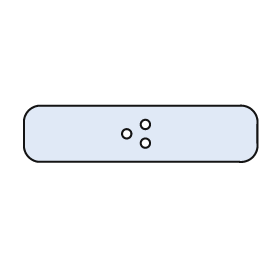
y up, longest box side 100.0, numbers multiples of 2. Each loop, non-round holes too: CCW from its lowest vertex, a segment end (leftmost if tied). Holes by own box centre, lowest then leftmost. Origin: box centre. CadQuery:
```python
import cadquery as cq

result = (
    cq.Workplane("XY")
    .moveTo(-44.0, -12.0)
    .lineTo(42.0, -12.0)
    .threePointArc((48.0, -10.0), (50.0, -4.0))
    .lineTo(50.0, 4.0)
    .threePointArc((48.0, 10.0), (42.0, 12.0))
    .lineTo(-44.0, 12.0)
    .threePointArc((-48.0, 10.0), (-50.0, 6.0))
    .lineTo(-50.0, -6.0)
    .threePointArc((-48.0, -10.0), (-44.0, -12.0))
    .close()
    .moveTo(2.0, -4.0)
    .circle(2.0)
    .moveTo(-6.0, 0.0)
    .circle(2.0)
    .moveTo(2.0, 4.0)
    .circle(2.0)
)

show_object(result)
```